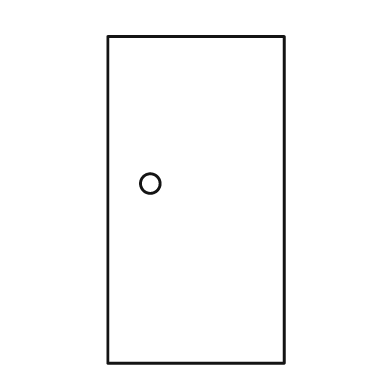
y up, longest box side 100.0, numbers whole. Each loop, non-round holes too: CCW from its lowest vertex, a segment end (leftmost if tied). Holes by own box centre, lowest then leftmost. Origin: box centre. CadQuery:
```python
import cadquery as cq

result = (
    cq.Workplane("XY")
    .moveTo(-27.0, -50.0)
    .lineTo(27.0, -50.0)
    .lineTo(27.0, 50.0)
    .lineTo(-27.0, 50.0)
    .close()
    .moveTo(-14.0, 5.0)
    .circle(3.0)
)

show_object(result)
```